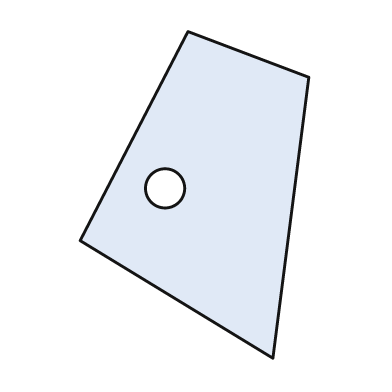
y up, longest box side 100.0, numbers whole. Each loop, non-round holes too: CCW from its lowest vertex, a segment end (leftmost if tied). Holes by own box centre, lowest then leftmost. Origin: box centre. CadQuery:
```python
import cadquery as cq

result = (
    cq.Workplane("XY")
    .moveTo(24.0, -50.0)
    .lineTo(35.0, 36.0)
    .lineTo(-2.0, 50.0)
    .lineTo(-35.0, -14.0)
    .close()
    .moveTo(-9.0, 2.0)
    .circle(6.0)
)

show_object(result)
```